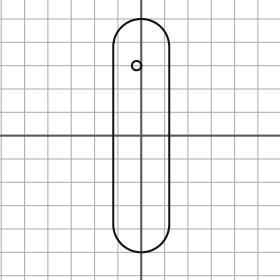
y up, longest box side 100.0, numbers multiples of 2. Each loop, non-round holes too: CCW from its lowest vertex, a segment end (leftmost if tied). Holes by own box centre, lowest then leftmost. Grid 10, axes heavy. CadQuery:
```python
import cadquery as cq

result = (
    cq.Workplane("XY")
    .moveTo(-12.0, -38.0)
    .threePointArc((0.0, -50.0), (12.0, -38.0))
    .lineTo(12.0, 38.0)
    .threePointArc((0.0, 50.0), (-12.0, 38.0))
    .close()
    .moveTo(-2.0, 30.0)
    .circle(2.0)
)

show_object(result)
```